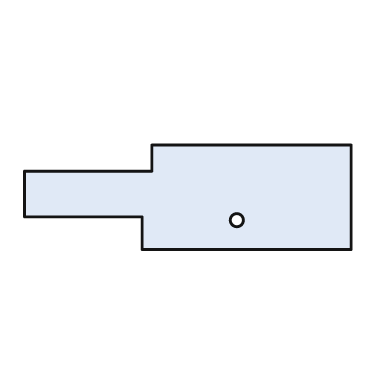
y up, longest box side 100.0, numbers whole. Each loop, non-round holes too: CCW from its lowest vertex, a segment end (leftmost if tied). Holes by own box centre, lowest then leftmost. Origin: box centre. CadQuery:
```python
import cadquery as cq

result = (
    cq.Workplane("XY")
    .moveTo(-14.0, -16.0)
    .lineTo(50.0, -16.0)
    .lineTo(50.0, 16.0)
    .lineTo(-11.0, 16.0)
    .lineTo(-11.0, 8.0)
    .lineTo(-50.0, 8.0)
    .lineTo(-50.0, -6.0)
    .lineTo(-14.0, -6.0)
    .close()
    .moveTo(15.0, -7.0)
    .circle(2.0)
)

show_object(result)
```